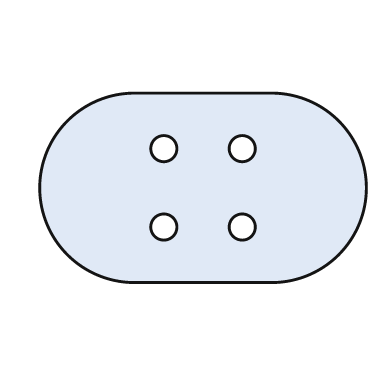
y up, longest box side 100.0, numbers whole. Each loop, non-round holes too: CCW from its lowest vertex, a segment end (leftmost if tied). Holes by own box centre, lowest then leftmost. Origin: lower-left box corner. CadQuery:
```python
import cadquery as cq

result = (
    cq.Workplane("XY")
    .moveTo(29.0, 0.0)
    .lineTo(71.0, 0.0)
    .threePointArc((100.0, 29.0), (71.0, 58.0))
    .lineTo(29.0, 58.0)
    .threePointArc((0.0, 29.0), (29.0, 0.0))
    .close()
    .moveTo(38.0, 17.0)
    .circle(4.0)
    .moveTo(62.0, 17.0)
    .circle(4.0)
    .moveTo(38.0, 41.0)
    .circle(4.0)
    .moveTo(62.0, 41.0)
    .circle(4.0)
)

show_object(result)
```